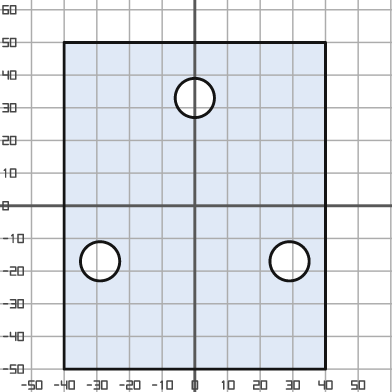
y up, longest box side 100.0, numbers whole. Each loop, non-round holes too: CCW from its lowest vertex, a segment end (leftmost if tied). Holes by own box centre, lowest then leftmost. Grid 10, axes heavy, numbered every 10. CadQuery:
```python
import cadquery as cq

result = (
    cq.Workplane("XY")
    .moveTo(-40.0, -50.0)
    .lineTo(40.0, -50.0)
    .lineTo(40.0, 50.0)
    .lineTo(-40.0, 50.0)
    .close()
    .moveTo(-29.0, -17.0)
    .circle(6.0)
    .moveTo(29.0, -17.0)
    .circle(6.0)
    .moveTo(0.0, 33.0)
    .circle(6.0)
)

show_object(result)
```